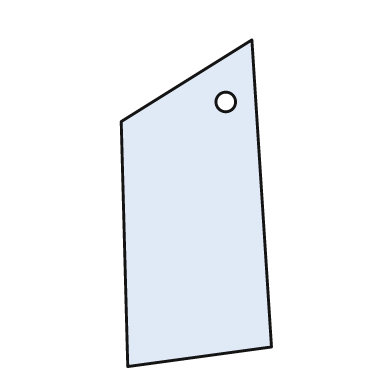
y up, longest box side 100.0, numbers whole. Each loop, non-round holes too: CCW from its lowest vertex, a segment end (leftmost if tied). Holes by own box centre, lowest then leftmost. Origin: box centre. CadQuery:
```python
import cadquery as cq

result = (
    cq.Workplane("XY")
    .moveTo(-21.0, -50.0)
    .lineTo(23.0, -44.0)
    .lineTo(17.0, 50.0)
    .lineTo(-23.0, 25.0)
    .close()
    .moveTo(9.0, 31.0)
    .circle(3.0)
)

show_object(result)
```